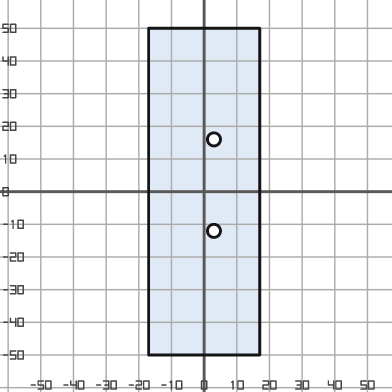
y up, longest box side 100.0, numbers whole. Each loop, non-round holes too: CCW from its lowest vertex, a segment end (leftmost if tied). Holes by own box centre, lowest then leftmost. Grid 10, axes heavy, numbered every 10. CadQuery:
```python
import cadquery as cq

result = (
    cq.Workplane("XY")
    .moveTo(-17.0, -50.0)
    .lineTo(17.0, -50.0)
    .lineTo(17.0, 50.0)
    .lineTo(-17.0, 50.0)
    .close()
    .moveTo(3.0, -12.0)
    .circle(2.0)
    .moveTo(3.0, 16.0)
    .circle(2.0)
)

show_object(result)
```